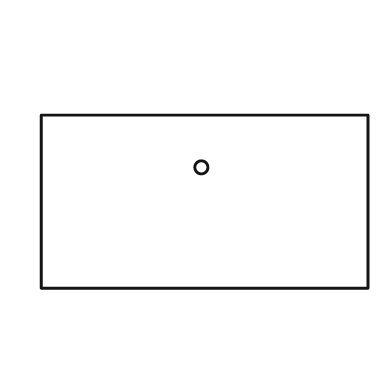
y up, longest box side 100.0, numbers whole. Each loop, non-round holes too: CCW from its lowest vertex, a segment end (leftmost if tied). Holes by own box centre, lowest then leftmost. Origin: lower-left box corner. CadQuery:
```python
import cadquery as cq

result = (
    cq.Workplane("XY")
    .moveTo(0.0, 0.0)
    .lineTo(100.0, 0.0)
    .lineTo(100.0, 53.0)
    .lineTo(0.0, 53.0)
    .close()
    .moveTo(49.0, 37.0)
    .circle(2.0)
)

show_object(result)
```